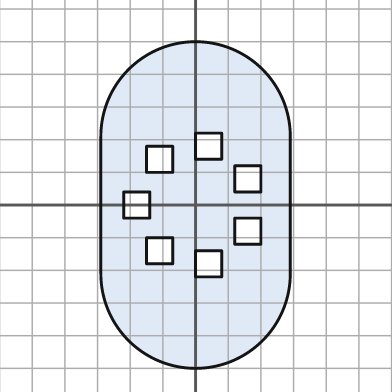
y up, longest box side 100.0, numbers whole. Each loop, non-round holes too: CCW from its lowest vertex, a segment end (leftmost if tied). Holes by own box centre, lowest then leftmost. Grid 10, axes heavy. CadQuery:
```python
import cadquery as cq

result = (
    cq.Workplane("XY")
    .moveTo(-29.0, -21.0)
    .threePointArc((0.0, -50.0), (29.0, -21.0))
    .lineTo(29.0, 21.0)
    .threePointArc((0.0, 50.0), (-29.0, 21.0))
    .close()
    .moveTo(0.0, -22.0)
    .lineTo(8.0, -22.0)
    .lineTo(8.0, -14.0)
    .lineTo(0.0, -14.0)
    .close()
    .moveTo(-15.0, -18.0)
    .lineTo(-7.0, -18.0)
    .lineTo(-7.0, -10.0)
    .lineTo(-15.0, -10.0)
    .close()
    .moveTo(12.0, -12.0)
    .lineTo(20.0, -12.0)
    .lineTo(20.0, -4.0)
    .lineTo(12.0, -4.0)
    .close()
    .moveTo(-22.0, -4.0)
    .lineTo(-14.0, -4.0)
    .lineTo(-14.0, 4.0)
    .lineTo(-22.0, 4.0)
    .close()
    .moveTo(12.0, 4.0)
    .lineTo(20.0, 4.0)
    .lineTo(20.0, 12.0)
    .lineTo(12.0, 12.0)
    .close()
    .moveTo(-15.0, 10.0)
    .lineTo(-7.0, 10.0)
    .lineTo(-7.0, 18.0)
    .lineTo(-15.0, 18.0)
    .close()
    .moveTo(0.0, 14.0)
    .lineTo(8.0, 14.0)
    .lineTo(8.0, 22.0)
    .lineTo(0.0, 22.0)
    .close()
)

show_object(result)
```